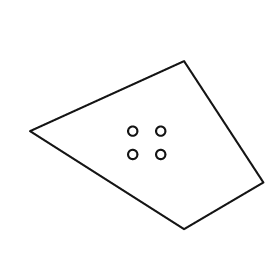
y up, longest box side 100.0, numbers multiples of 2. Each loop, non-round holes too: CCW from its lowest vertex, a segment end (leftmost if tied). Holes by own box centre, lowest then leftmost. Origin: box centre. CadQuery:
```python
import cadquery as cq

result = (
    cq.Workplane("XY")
    .moveTo(16.0, -36.0)
    .lineTo(50.0, -16.0)
    .lineTo(16.0, 36.0)
    .lineTo(-50.0, 6.0)
    .close()
    .moveTo(-6.0, -4.0)
    .circle(2.0)
    .moveTo(6.0, -4.0)
    .circle(2.0)
    .moveTo(-6.0, 6.0)
    .circle(2.0)
    .moveTo(6.0, 6.0)
    .circle(2.0)
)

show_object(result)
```